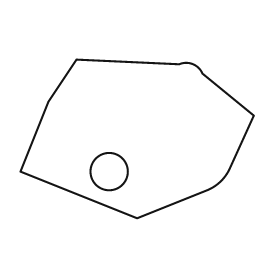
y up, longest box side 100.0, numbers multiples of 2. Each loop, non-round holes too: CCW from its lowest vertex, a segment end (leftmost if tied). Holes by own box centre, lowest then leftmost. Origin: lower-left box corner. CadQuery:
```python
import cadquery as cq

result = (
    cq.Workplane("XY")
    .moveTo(50.0, 0.0)
    .lineTo(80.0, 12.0)
    .threePointArc((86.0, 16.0), (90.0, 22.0))
    .lineTo(100.0, 44.0)
    .lineTo(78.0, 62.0)
    .threePointArc((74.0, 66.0), (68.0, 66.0))
    .lineTo(24.0, 68.0)
    .lineTo(12.0, 50.0)
    .lineTo(0.0, 20.0)
    .close()
    .moveTo(38.0, 20.0)
    .circle(8.0)
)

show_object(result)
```